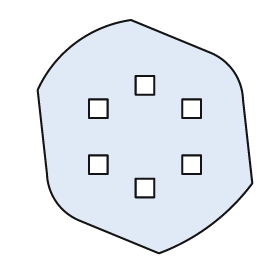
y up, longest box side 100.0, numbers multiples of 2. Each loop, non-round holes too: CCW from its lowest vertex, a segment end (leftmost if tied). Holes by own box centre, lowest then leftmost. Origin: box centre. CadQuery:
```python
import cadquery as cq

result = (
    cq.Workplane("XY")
    .moveTo(6.0, -50.0)
    .threePointArc((28.0, -38.0), (46.0, -20.0))
    .lineTo(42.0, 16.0)
    .threePointArc((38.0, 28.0), (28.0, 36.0))
    .lineTo(-6.0, 50.0)
    .threePointArc((-30.0, 40.0), (-46.0, 20.0))
    .lineTo(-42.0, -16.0)
    .threePointArc((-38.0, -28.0), (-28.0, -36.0))
    .close()
    .moveTo(-4.0, -26.0)
    .lineTo(4.0, -26.0)
    .lineTo(4.0, -18.0)
    .lineTo(-4.0, -18.0)
    .close()
    .moveTo(-24.0, -16.0)
    .lineTo(-16.0, -16.0)
    .lineTo(-16.0, -8.0)
    .lineTo(-24.0, -8.0)
    .close()
    .moveTo(16.0, -16.0)
    .lineTo(24.0, -16.0)
    .lineTo(24.0, -8.0)
    .lineTo(16.0, -8.0)
    .close()
    .moveTo(-24.0, 8.0)
    .lineTo(-16.0, 8.0)
    .lineTo(-16.0, 16.0)
    .lineTo(-24.0, 16.0)
    .close()
    .moveTo(16.0, 8.0)
    .lineTo(24.0, 8.0)
    .lineTo(24.0, 16.0)
    .lineTo(16.0, 16.0)
    .close()
    .moveTo(-4.0, 18.0)
    .lineTo(4.0, 18.0)
    .lineTo(4.0, 26.0)
    .lineTo(-4.0, 26.0)
    .close()
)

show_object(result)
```